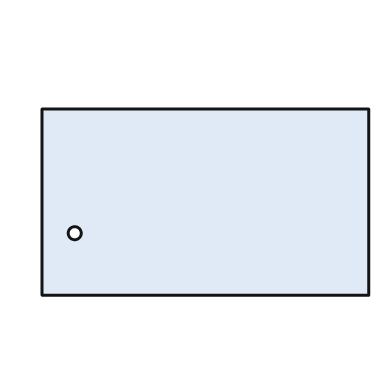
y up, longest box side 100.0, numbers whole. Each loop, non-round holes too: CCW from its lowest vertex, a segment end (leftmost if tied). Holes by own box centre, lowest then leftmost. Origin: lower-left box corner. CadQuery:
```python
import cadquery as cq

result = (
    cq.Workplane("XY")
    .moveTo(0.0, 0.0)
    .lineTo(100.0, 0.0)
    .lineTo(100.0, 57.0)
    .lineTo(0.0, 57.0)
    .close()
    .moveTo(10.0, 19.0)
    .circle(2.0)
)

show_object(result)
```